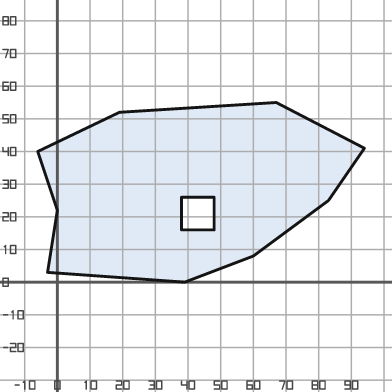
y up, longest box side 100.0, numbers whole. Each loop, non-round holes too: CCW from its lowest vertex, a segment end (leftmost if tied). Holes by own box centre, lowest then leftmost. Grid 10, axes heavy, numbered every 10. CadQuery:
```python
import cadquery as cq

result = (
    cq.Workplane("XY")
    .moveTo(39.0, 0.0)
    .lineTo(60.0, 8.0)
    .lineTo(83.0, 25.0)
    .lineTo(94.0, 41.0)
    .lineTo(67.0, 55.0)
    .lineTo(19.0, 52.0)
    .lineTo(-6.0, 40.0)
    .lineTo(0.0, 22.0)
    .lineTo(-3.0, 3.0)
    .close()
    .moveTo(38.0, 16.0)
    .lineTo(48.0, 16.0)
    .lineTo(48.0, 26.0)
    .lineTo(38.0, 26.0)
    .close()
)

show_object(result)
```